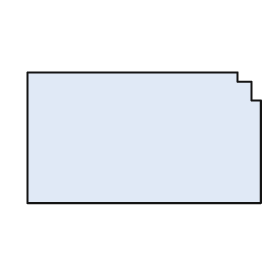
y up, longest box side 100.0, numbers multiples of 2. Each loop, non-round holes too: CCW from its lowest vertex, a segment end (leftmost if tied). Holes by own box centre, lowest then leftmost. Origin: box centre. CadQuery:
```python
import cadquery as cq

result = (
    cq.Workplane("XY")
    .moveTo(-50.0, -28.0)
    .lineTo(50.0, -28.0)
    .lineTo(50.0, 16.0)
    .lineTo(46.0, 16.0)
    .lineTo(46.0, 24.0)
    .lineTo(40.0, 24.0)
    .lineTo(40.0, 28.0)
    .lineTo(-50.0, 28.0)
    .close()
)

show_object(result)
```